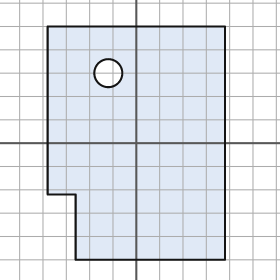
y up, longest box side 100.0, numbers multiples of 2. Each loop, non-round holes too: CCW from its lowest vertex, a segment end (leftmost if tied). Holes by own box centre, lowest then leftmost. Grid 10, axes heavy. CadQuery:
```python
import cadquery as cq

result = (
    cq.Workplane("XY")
    .moveTo(-26.0, -50.0)
    .lineTo(38.0, -50.0)
    .lineTo(38.0, 50.0)
    .lineTo(-38.0, 50.0)
    .lineTo(-38.0, -22.0)
    .lineTo(-26.0, -22.0)
    .close()
    .moveTo(-12.0, 30.0)
    .circle(6.0)
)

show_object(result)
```